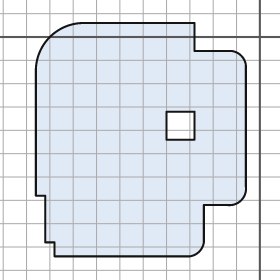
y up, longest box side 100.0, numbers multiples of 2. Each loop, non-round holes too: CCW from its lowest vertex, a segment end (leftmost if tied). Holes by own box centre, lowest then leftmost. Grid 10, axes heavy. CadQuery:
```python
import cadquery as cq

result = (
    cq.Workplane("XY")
    .moveTo(-88.0, -94.0)
    .lineTo(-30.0, -94.0)
    .threePointArc((-26.0, -92.0), (-24.0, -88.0))
    .lineTo(-24.0, -72.0)
    .lineTo(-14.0, -72.0)
    .threePointArc((-8.0, -70.0), (-6.0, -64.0))
    .lineTo(-6.0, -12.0)
    .threePointArc((-8.0, -8.0), (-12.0, -6.0))
    .lineTo(-28.0, -6.0)
    .lineTo(-28.0, 6.0)
    .lineTo(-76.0, 6.0)
    .threePointArc((-90.0, 0.0), (-96.0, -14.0))
    .lineTo(-96.0, -68.0)
    .lineTo(-92.0, -68.0)
    .lineTo(-92.0, -88.0)
    .lineTo(-88.0, -88.0)
    .close()
    .moveTo(-40.0, -44.0)
    .lineTo(-28.0, -44.0)
    .lineTo(-28.0, -32.0)
    .lineTo(-40.0, -32.0)
    .close()
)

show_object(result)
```